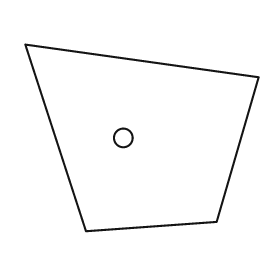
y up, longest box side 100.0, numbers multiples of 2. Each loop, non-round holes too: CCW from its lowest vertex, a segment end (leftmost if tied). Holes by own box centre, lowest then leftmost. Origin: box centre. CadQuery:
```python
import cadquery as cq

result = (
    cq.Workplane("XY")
    .moveTo(-24.0, -40.0)
    .lineTo(32.0, -36.0)
    .lineTo(50.0, 26.0)
    .lineTo(-50.0, 40.0)
    .close()
    .moveTo(-8.0, 0.0)
    .circle(4.0)
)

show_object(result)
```